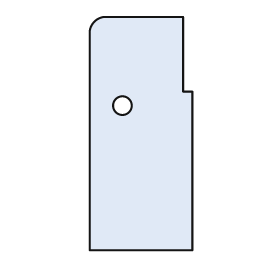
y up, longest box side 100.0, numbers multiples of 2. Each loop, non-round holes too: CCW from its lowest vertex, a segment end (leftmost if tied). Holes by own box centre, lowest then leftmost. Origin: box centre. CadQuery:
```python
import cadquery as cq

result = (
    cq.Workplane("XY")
    .moveTo(-22.0, -50.0)
    .lineTo(22.0, -50.0)
    .lineTo(22.0, 18.0)
    .lineTo(18.0, 18.0)
    .lineTo(18.0, 50.0)
    .lineTo(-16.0, 50.0)
    .threePointArc((-20.0, 48.0), (-22.0, 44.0))
    .close()
    .moveTo(-8.0, 12.0)
    .circle(4.0)
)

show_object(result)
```